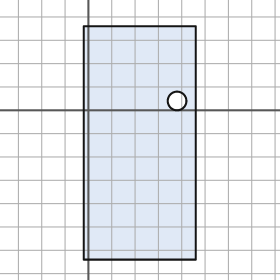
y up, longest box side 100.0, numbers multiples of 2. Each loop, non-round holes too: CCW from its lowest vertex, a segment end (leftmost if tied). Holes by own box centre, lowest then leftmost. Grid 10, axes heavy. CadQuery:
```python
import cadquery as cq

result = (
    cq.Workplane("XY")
    .moveTo(-2.0, -64.0)
    .lineTo(46.0, -64.0)
    .lineTo(46.0, 36.0)
    .lineTo(-2.0, 36.0)
    .close()
    .moveTo(38.0, 4.0)
    .circle(4.0)
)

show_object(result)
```